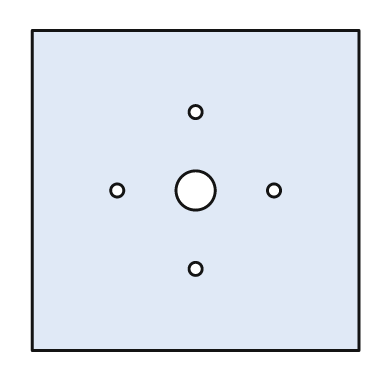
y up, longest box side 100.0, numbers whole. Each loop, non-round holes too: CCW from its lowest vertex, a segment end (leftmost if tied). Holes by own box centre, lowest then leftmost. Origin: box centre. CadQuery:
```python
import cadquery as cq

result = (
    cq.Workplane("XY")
    .moveTo(-50.0, -49.0)
    .lineTo(50.0, -49.0)
    .lineTo(50.0, 49.0)
    .lineTo(-50.0, 49.0)
    .close()
    .moveTo(0.0, -24.0)
    .circle(2.0)
    .moveTo(-24.0, 0.0)
    .circle(2.0)
    .moveTo(0.0, 0.0)
    .circle(6.0)
    .moveTo(24.0, 0.0)
    .circle(2.0)
    .moveTo(0.0, 24.0)
    .circle(2.0)
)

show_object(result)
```